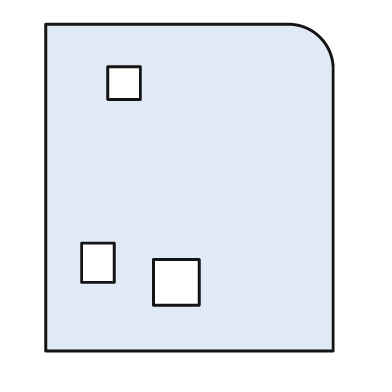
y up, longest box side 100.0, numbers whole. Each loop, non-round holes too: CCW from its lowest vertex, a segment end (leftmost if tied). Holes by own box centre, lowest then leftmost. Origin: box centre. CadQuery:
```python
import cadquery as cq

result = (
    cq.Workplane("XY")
    .moveTo(-44.0, -50.0)
    .lineTo(44.0, -50.0)
    .lineTo(44.0, 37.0)
    .threePointArc((40.0, 46.0), (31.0, 50.0))
    .lineTo(-44.0, 50.0)
    .close()
    .moveTo(-11.0, -36.0)
    .lineTo(3.0, -36.0)
    .lineTo(3.0, -22.0)
    .lineTo(-11.0, -22.0)
    .close()
    .moveTo(-33.0, -29.0)
    .lineTo(-23.0, -29.0)
    .lineTo(-23.0, -17.0)
    .lineTo(-33.0, -17.0)
    .close()
    .moveTo(-25.0, 27.0)
    .lineTo(-15.0, 27.0)
    .lineTo(-15.0, 37.0)
    .lineTo(-25.0, 37.0)
    .close()
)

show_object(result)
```